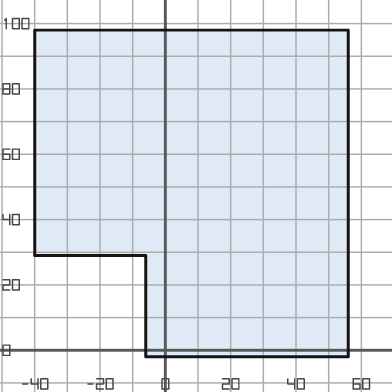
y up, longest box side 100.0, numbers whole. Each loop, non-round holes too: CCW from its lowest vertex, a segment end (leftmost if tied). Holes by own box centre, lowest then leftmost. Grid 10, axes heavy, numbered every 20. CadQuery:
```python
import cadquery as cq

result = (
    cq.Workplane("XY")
    .moveTo(-6.0, -2.0)
    .lineTo(56.0, -2.0)
    .lineTo(56.0, 98.0)
    .lineTo(-40.0, 98.0)
    .lineTo(-40.0, 29.0)
    .lineTo(-6.0, 29.0)
    .close()
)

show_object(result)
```